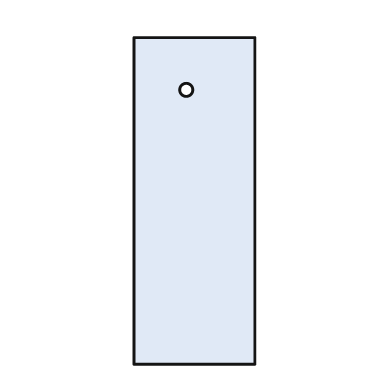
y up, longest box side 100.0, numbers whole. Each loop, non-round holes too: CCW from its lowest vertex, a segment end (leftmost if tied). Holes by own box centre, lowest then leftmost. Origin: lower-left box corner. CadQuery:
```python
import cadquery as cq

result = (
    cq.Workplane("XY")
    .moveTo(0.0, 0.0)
    .lineTo(37.0, 0.0)
    .lineTo(37.0, 100.0)
    .lineTo(0.0, 100.0)
    .close()
    .moveTo(16.0, 84.0)
    .circle(2.0)
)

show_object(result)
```